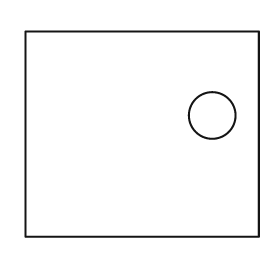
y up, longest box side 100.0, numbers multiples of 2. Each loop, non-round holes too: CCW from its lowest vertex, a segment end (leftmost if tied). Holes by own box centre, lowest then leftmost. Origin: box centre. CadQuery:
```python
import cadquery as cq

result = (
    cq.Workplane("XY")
    .moveTo(-50.0, -44.0)
    .lineTo(50.0, -44.0)
    .lineTo(50.0, 44.0)
    .lineTo(-50.0, 44.0)
    .close()
    .moveTo(30.0, 8.0)
    .circle(10.0)
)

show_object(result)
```